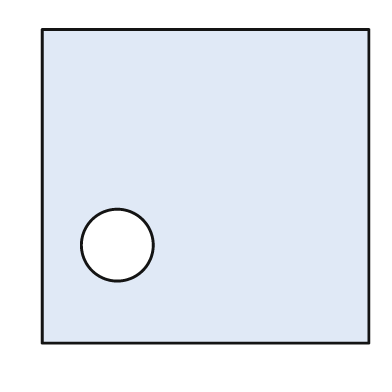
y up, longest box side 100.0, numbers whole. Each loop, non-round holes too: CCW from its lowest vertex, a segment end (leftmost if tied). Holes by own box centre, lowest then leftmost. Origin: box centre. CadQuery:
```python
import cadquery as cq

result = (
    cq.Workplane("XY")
    .moveTo(-50.0, -48.0)
    .lineTo(50.0, -48.0)
    .lineTo(50.0, 48.0)
    .lineTo(-50.0, 48.0)
    .close()
    .moveTo(-27.0, -18.0)
    .circle(11.0)
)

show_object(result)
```